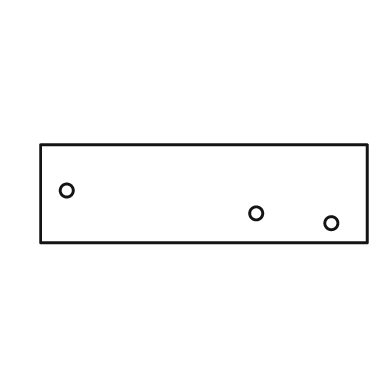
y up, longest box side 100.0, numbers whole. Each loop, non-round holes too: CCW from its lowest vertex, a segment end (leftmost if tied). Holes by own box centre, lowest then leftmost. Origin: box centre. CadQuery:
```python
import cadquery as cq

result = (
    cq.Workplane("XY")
    .moveTo(-50.0, -15.0)
    .lineTo(50.0, -15.0)
    .lineTo(50.0, 15.0)
    .lineTo(-50.0, 15.0)
    .close()
    .moveTo(39.0, -9.0)
    .circle(2.0)
    .moveTo(16.0, -6.0)
    .circle(2.0)
    .moveTo(-42.0, 1.0)
    .circle(2.0)
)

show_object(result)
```